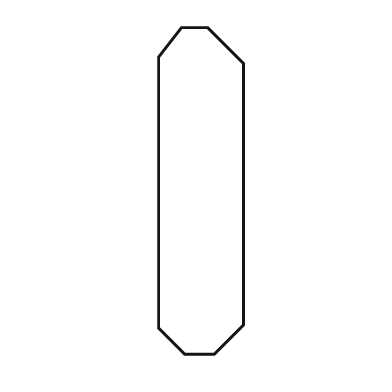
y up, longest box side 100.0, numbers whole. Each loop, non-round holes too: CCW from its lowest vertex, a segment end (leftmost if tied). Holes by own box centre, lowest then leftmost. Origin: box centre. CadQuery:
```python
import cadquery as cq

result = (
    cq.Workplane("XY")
    .moveTo(-5.0, -50.0)
    .lineTo(4.0, -50.0)
    .lineTo(13.0, -41.0)
    .lineTo(13.0, 39.0)
    .lineTo(2.0, 50.0)
    .lineTo(-6.0, 50.0)
    .lineTo(-13.0, 41.0)
    .lineTo(-13.0, -42.0)
    .close()
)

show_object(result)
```